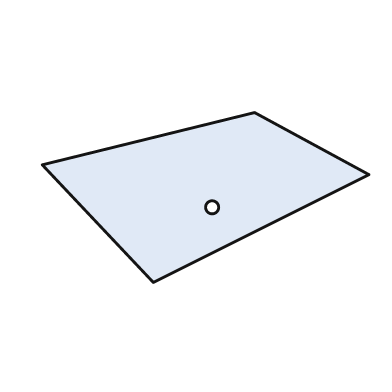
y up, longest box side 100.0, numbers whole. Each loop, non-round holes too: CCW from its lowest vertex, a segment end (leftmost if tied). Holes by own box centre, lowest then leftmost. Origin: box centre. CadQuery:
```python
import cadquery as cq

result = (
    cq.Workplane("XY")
    .moveTo(-16.0, -26.0)
    .lineTo(50.0, 7.0)
    .lineTo(15.0, 26.0)
    .lineTo(-50.0, 10.0)
    .close()
    .moveTo(2.0, -3.0)
    .circle(2.0)
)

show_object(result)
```